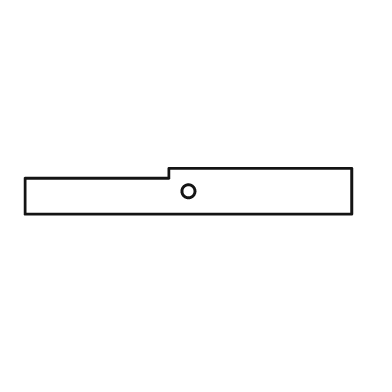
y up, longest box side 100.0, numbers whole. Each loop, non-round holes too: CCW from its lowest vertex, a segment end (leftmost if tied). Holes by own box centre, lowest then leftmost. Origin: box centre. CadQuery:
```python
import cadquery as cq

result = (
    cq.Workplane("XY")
    .moveTo(-50.0, -7.0)
    .lineTo(50.0, -7.0)
    .lineTo(50.0, 7.0)
    .lineTo(-6.0, 7.0)
    .lineTo(-6.0, 4.0)
    .lineTo(-50.0, 4.0)
    .close()
    .moveTo(0.0, 0.0)
    .circle(2.0)
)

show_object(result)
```